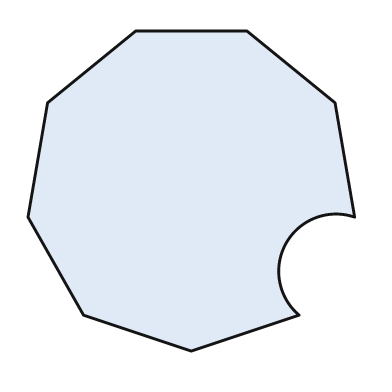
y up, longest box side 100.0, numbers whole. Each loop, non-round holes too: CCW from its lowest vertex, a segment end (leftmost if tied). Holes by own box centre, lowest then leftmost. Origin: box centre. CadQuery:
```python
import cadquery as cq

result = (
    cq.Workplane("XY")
    .moveTo(0.0, -49.0)
    .lineTo(33.0, -38.0)
    .threePointArc((29.0, -16.0), (50.0, -8.0))
    .lineTo(44.0, 27.0)
    .lineTo(17.0, 49.0)
    .lineTo(-17.0, 49.0)
    .lineTo(-44.0, 27.0)
    .lineTo(-50.0, -8.0)
    .lineTo(-33.0, -38.0)
    .close()
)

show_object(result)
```